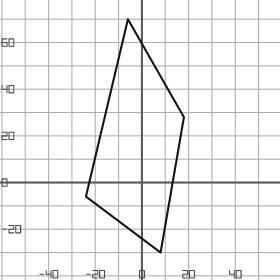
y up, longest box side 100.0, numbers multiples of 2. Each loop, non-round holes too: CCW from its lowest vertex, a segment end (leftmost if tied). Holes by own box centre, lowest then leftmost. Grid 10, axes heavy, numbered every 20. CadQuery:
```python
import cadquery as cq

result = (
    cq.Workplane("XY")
    .moveTo(8.0, -30.0)
    .lineTo(18.0, 28.0)
    .lineTo(-6.0, 70.0)
    .lineTo(-24.0, -6.0)
    .close()
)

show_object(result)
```